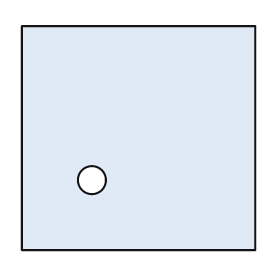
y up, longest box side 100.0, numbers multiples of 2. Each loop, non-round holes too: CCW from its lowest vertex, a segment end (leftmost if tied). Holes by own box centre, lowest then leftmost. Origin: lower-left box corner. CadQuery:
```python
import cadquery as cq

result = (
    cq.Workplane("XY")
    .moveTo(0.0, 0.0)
    .lineTo(100.0, 0.0)
    .lineTo(100.0, 96.0)
    .lineTo(0.0, 96.0)
    .close()
    .moveTo(30.0, 30.0)
    .circle(6.0)
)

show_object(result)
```